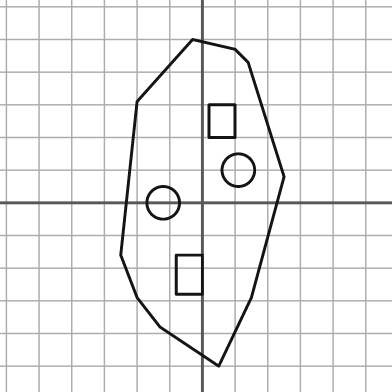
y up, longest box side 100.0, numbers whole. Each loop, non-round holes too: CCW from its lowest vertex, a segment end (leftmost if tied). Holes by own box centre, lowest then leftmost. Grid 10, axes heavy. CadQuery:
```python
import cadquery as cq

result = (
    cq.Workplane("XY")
    .moveTo(5.0, -50.0)
    .lineTo(15.0, -29.0)
    .lineTo(25.0, 8.0)
    .lineTo(14.0, 43.0)
    .lineTo(10.0, 47.0)
    .lineTo(-3.0, 50.0)
    .lineTo(-20.0, 31.0)
    .lineTo(-25.0, -16.0)
    .lineTo(-20.0, -29.0)
    .lineTo(-13.0, -38.0)
    .close()
    .moveTo(-8.0, -28.0)
    .lineTo(0.0, -28.0)
    .lineTo(0.0, -16.0)
    .lineTo(-8.0, -16.0)
    .close()
    .moveTo(-12.0, 0.0)
    .circle(5.0)
    .moveTo(11.0, 10.0)
    .circle(5.0)
    .moveTo(2.0, 20.0)
    .lineTo(10.0, 20.0)
    .lineTo(10.0, 30.0)
    .lineTo(2.0, 30.0)
    .close()
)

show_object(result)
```